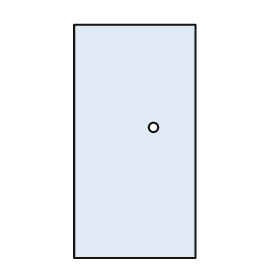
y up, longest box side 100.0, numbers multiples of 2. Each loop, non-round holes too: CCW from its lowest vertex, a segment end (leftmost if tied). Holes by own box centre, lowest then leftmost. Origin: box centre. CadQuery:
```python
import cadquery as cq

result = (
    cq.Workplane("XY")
    .moveTo(-26.0, -50.0)
    .lineTo(26.0, -50.0)
    .lineTo(26.0, 50.0)
    .lineTo(-26.0, 50.0)
    .close()
    .moveTo(8.0, 6.0)
    .circle(2.0)
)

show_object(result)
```